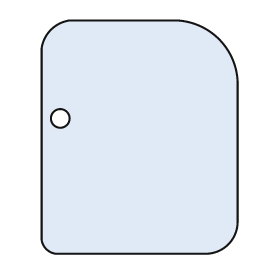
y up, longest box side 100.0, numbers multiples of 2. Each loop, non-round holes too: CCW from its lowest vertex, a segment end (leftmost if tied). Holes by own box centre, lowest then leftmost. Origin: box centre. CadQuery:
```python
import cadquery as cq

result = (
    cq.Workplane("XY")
    .moveTo(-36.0, -50.0)
    .lineTo(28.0, -50.0)
    .threePointArc((38.0, -46.0), (42.0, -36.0))
    .lineTo(42.0, 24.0)
    .threePointArc((34.0, 42.0), (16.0, 50.0))
    .lineTo(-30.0, 50.0)
    .threePointArc((-38.0, 46.0), (-42.0, 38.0))
    .lineTo(-42.0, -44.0)
    .threePointArc((-40.0, -48.0), (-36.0, -50.0))
    .close()
    .moveTo(-34.0, 8.0)
    .circle(4.0)
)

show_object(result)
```